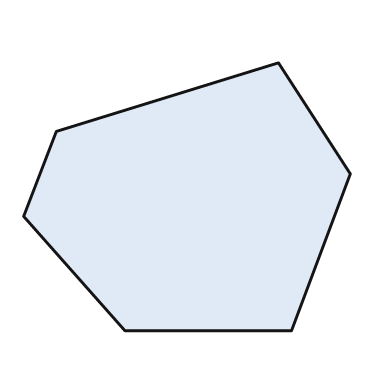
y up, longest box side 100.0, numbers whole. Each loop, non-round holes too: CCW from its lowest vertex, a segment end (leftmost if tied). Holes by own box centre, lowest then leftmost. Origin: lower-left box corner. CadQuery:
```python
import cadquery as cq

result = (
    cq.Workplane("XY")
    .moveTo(31.0, 0.0)
    .lineTo(82.0, 0.0)
    .lineTo(100.0, 48.0)
    .lineTo(78.0, 82.0)
    .lineTo(10.0, 61.0)
    .lineTo(0.0, 35.0)
    .close()
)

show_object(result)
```